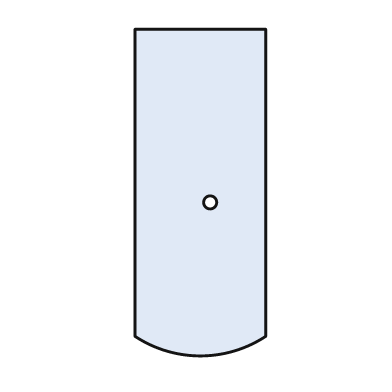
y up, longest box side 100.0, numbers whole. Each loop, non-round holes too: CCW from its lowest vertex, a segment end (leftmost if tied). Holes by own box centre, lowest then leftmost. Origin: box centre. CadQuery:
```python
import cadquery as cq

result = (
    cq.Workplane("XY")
    .moveTo(-20.0, -44.0)
    .threePointArc((0.0, -50.0), (20.0, -44.0))
    .lineTo(20.0, 50.0)
    .lineTo(-20.0, 50.0)
    .close()
    .moveTo(3.0, -3.0)
    .circle(2.0)
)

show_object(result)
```